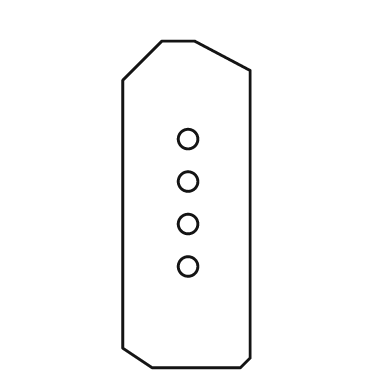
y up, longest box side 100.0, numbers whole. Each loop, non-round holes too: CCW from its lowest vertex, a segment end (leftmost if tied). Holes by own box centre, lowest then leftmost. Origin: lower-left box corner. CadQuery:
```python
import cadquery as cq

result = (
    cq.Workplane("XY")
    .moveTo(9.0, 0.0)
    .lineTo(36.0, 0.0)
    .lineTo(39.0, 3.0)
    .lineTo(39.0, 91.0)
    .lineTo(22.0, 100.0)
    .lineTo(12.0, 100.0)
    .lineTo(0.0, 88.0)
    .lineTo(0.0, 6.0)
    .close()
    .moveTo(20.0, 31.0)
    .circle(3.0)
    .moveTo(20.0, 44.0)
    .circle(3.0)
    .moveTo(20.0, 57.0)
    .circle(3.0)
    .moveTo(20.0, 70.0)
    .circle(3.0)
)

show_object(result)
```